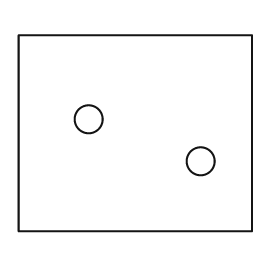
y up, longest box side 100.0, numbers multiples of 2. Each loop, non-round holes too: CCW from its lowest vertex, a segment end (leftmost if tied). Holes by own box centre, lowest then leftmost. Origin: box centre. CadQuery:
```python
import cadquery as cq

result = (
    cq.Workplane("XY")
    .moveTo(-50.0, -42.0)
    .lineTo(50.0, -42.0)
    .lineTo(50.0, 42.0)
    .lineTo(-50.0, 42.0)
    .close()
    .moveTo(28.0, -12.0)
    .circle(6.0)
    .moveTo(-20.0, 6.0)
    .circle(6.0)
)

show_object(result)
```